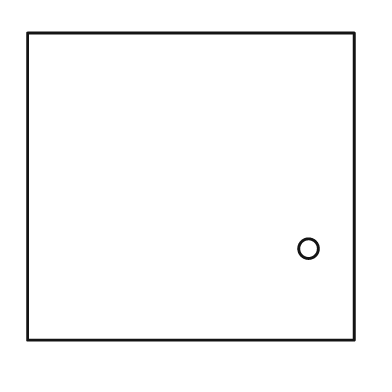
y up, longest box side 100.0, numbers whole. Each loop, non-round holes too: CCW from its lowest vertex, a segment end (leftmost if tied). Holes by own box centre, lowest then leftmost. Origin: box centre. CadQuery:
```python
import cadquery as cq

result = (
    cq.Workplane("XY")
    .moveTo(-50.0, -47.0)
    .lineTo(50.0, -47.0)
    .lineTo(50.0, 47.0)
    .lineTo(-50.0, 47.0)
    .close()
    .moveTo(36.0, -19.0)
    .circle(3.0)
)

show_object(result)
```